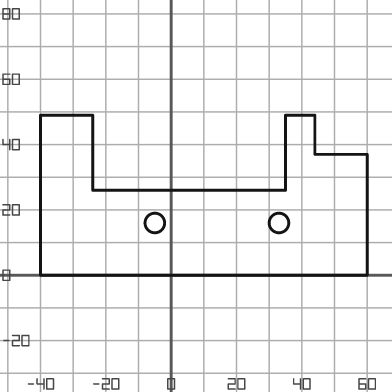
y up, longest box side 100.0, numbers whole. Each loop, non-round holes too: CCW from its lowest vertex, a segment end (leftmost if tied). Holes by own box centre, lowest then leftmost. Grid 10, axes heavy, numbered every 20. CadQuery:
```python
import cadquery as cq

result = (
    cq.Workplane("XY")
    .moveTo(-40.0, 0.0)
    .lineTo(60.0, 0.0)
    .lineTo(60.0, 37.0)
    .lineTo(44.0, 37.0)
    .lineTo(44.0, 49.0)
    .lineTo(35.0, 49.0)
    .lineTo(35.0, 26.0)
    .lineTo(-24.0, 26.0)
    .lineTo(-24.0, 49.0)
    .lineTo(-40.0, 49.0)
    .close()
    .moveTo(-5.0, 16.0)
    .circle(3.0)
    .moveTo(33.0, 16.0)
    .circle(3.0)
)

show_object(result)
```